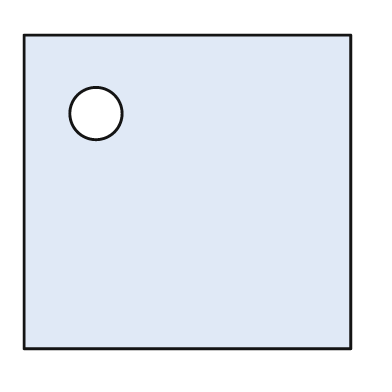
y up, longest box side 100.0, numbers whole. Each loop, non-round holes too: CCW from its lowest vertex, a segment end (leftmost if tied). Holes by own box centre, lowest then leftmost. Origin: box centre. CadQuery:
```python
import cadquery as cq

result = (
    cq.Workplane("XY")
    .moveTo(-50.0, -48.0)
    .lineTo(50.0, -48.0)
    .lineTo(50.0, 48.0)
    .lineTo(-50.0, 48.0)
    .close()
    .moveTo(-28.0, 24.0)
    .circle(8.0)
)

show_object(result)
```